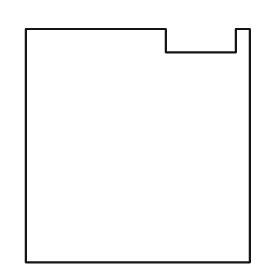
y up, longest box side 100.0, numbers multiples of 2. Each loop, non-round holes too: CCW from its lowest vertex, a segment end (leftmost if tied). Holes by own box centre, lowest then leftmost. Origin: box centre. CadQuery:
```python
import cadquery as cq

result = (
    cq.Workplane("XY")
    .moveTo(-48.0, -50.0)
    .lineTo(48.0, -50.0)
    .lineTo(48.0, 50.0)
    .lineTo(42.0, 50.0)
    .lineTo(42.0, 40.0)
    .lineTo(12.0, 40.0)
    .lineTo(12.0, 50.0)
    .lineTo(-48.0, 50.0)
    .close()
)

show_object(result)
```